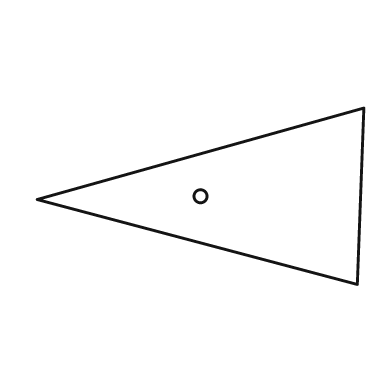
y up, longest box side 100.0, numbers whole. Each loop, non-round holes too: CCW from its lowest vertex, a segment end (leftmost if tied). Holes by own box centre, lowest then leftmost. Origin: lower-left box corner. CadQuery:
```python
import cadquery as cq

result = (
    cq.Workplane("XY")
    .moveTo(98.0, 0.0)
    .lineTo(100.0, 54.0)
    .lineTo(0.0, 26.0)
    .close()
    .moveTo(50.0, 27.0)
    .circle(2.0)
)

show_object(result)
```